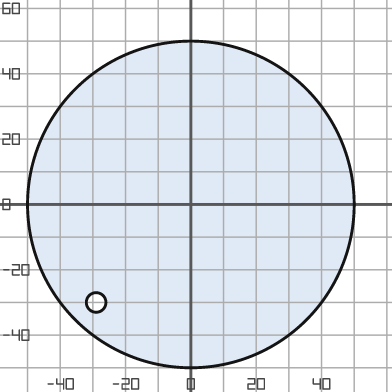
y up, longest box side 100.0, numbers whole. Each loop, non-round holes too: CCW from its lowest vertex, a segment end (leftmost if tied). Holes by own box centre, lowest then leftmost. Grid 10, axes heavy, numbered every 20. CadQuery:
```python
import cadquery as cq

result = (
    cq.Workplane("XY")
    .moveTo(0.0, 0.0)
    .circle(50.0)
    .moveTo(-29.0, -30.0)
    .circle(3.0)
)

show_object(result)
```